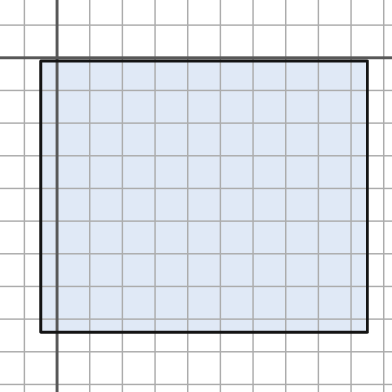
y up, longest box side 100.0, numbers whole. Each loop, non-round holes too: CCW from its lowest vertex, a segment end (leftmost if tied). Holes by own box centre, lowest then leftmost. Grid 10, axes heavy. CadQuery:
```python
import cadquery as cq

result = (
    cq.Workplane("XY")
    .moveTo(-5.0, -84.0)
    .lineTo(95.0, -84.0)
    .lineTo(95.0, -1.0)
    .lineTo(-5.0, -1.0)
    .close()
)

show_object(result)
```